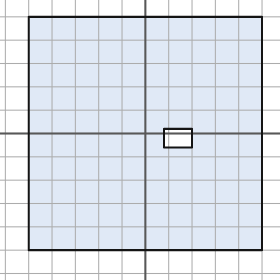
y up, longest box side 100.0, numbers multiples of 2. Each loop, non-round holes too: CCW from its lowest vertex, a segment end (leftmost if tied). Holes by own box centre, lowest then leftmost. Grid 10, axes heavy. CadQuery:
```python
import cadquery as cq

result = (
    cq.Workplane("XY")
    .moveTo(-50.0, -50.0)
    .lineTo(50.0, -50.0)
    .lineTo(50.0, 50.0)
    .lineTo(-50.0, 50.0)
    .close()
    .moveTo(8.0, -6.0)
    .lineTo(20.0, -6.0)
    .lineTo(20.0, 2.0)
    .lineTo(8.0, 2.0)
    .close()
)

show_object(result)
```